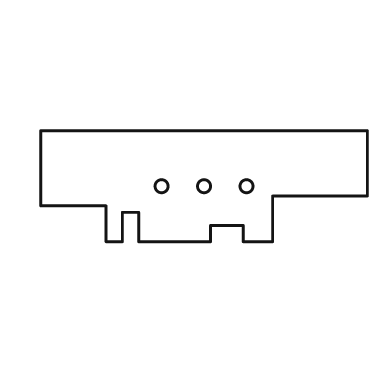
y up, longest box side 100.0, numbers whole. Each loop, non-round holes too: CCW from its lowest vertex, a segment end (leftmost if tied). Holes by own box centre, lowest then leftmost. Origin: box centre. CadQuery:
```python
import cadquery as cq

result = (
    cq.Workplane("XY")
    .moveTo(-30.0, -17.0)
    .lineTo(-25.0, -17.0)
    .lineTo(-25.0, -8.0)
    .lineTo(-20.0, -8.0)
    .lineTo(-20.0, -17.0)
    .lineTo(2.0, -17.0)
    .lineTo(2.0, -12.0)
    .lineTo(12.0, -12.0)
    .lineTo(12.0, -17.0)
    .lineTo(21.0, -17.0)
    .lineTo(21.0, -3.0)
    .lineTo(50.0, -3.0)
    .lineTo(50.0, 17.0)
    .lineTo(-50.0, 17.0)
    .lineTo(-50.0, -6.0)
    .lineTo(-30.0, -6.0)
    .close()
    .moveTo(-13.0, 0.0)
    .circle(2.0)
    .moveTo(0.0, 0.0)
    .circle(2.0)
    .moveTo(13.0, 0.0)
    .circle(2.0)
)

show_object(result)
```